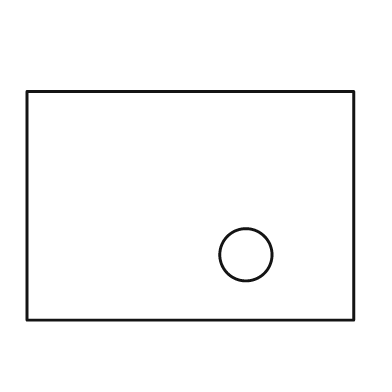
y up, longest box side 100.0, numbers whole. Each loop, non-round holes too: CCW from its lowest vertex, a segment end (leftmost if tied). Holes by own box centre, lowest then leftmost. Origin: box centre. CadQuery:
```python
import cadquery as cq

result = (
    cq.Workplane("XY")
    .moveTo(-50.0, -35.0)
    .lineTo(50.0, -35.0)
    .lineTo(50.0, 35.0)
    .lineTo(-50.0, 35.0)
    .close()
    .moveTo(17.0, -15.0)
    .circle(8.0)
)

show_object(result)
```